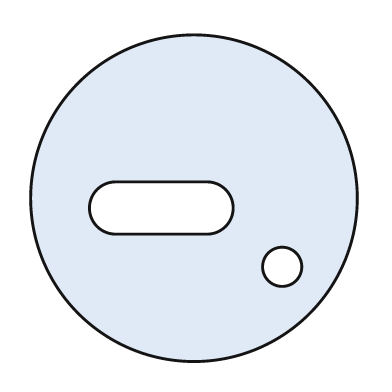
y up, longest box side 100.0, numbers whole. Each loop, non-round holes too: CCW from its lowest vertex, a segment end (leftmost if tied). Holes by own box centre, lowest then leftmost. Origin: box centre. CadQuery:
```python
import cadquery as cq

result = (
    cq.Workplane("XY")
    .moveTo(0.0, 0.0)
    .circle(50.0)
    .moveTo(27.0, -21.0)
    .circle(6.0)
    .moveTo(-24.0, -11.0)
    .lineTo(4.0, -11.0)
    .threePointArc((12.0, -3.0), (4.0, 5.0))
    .lineTo(-24.0, 5.0)
    .threePointArc((-32.0, -3.0), (-24.0, -11.0))
    .close()
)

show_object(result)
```